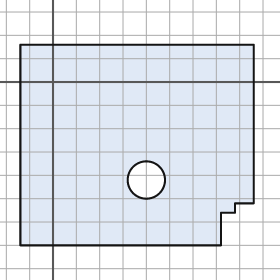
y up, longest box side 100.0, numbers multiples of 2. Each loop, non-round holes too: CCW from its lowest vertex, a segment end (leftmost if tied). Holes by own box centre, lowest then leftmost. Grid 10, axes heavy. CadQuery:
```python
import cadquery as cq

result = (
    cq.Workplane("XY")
    .moveTo(-14.0, -70.0)
    .lineTo(72.0, -70.0)
    .lineTo(72.0, -56.0)
    .lineTo(78.0, -56.0)
    .lineTo(78.0, -52.0)
    .lineTo(86.0, -52.0)
    .lineTo(86.0, 16.0)
    .lineTo(-14.0, 16.0)
    .close()
    .moveTo(40.0, -42.0)
    .circle(8.0)
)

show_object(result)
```